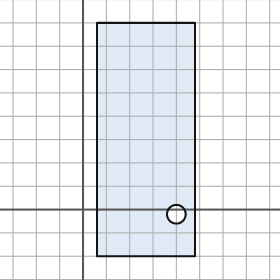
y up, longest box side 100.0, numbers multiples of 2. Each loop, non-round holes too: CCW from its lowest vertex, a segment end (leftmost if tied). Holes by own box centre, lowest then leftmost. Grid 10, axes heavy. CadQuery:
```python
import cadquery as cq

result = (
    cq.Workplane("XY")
    .moveTo(6.0, -20.0)
    .lineTo(48.0, -20.0)
    .lineTo(48.0, 80.0)
    .lineTo(6.0, 80.0)
    .close()
    .moveTo(40.0, -2.0)
    .circle(4.0)
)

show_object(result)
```